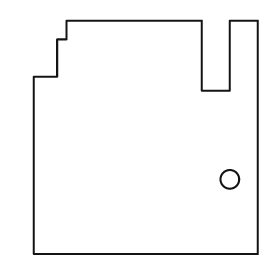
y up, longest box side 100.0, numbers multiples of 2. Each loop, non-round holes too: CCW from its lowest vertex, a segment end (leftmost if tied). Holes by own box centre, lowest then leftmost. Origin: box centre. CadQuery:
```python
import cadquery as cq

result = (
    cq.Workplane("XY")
    .moveTo(-48.0, -50.0)
    .lineTo(48.0, -50.0)
    .lineTo(48.0, 50.0)
    .lineTo(36.0, 50.0)
    .lineTo(36.0, 20.0)
    .lineTo(24.0, 20.0)
    .lineTo(24.0, 50.0)
    .lineTo(-34.0, 50.0)
    .lineTo(-34.0, 42.0)
    .lineTo(-38.0, 42.0)
    .lineTo(-38.0, 26.0)
    .lineTo(-48.0, 26.0)
    .close()
    .moveTo(36.0, -18.0)
    .circle(4.0)
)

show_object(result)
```